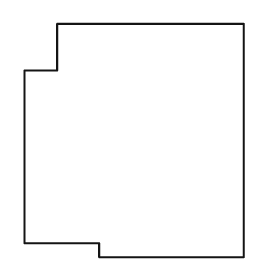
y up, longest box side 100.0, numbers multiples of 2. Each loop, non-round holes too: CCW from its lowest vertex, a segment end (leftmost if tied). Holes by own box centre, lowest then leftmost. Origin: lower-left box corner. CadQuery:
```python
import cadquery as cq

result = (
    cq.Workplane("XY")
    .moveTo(32.0, 0.0)
    .lineTo(94.0, 0.0)
    .lineTo(94.0, 100.0)
    .lineTo(14.0, 100.0)
    .lineTo(14.0, 80.0)
    .lineTo(0.0, 80.0)
    .lineTo(0.0, 6.0)
    .lineTo(32.0, 6.0)
    .close()
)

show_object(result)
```